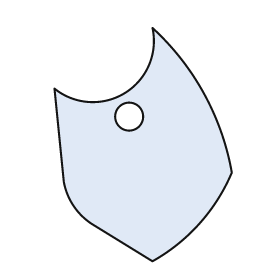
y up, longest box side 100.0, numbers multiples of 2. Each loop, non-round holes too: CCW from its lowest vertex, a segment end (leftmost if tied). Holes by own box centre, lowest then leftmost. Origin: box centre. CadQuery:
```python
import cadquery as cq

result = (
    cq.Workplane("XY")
    .moveTo(4.0, -50.0)
    .threePointArc((24.0, -34.0), (38.0, -12.0))
    .threePointArc((26.0, 22.0), (4.0, 50.0))
    .threePointArc((-8.0, 22.0), (-38.0, 24.0))
    .lineTo(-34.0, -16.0)
    .threePointArc((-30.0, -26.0), (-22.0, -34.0))
    .close()
    .moveTo(-6.0, 12.0)
    .circle(6.0)
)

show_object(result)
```